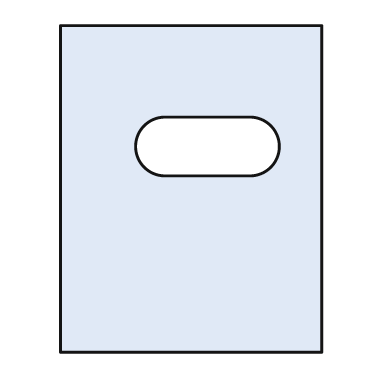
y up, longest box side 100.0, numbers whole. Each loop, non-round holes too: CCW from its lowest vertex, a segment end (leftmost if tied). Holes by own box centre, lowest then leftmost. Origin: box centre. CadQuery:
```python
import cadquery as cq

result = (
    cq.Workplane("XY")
    .moveTo(-40.0, -50.0)
    .lineTo(40.0, -50.0)
    .lineTo(40.0, 50.0)
    .lineTo(-40.0, 50.0)
    .close()
    .moveTo(-8.0, 4.0)
    .lineTo(18.0, 4.0)
    .threePointArc((27.0, 13.0), (18.0, 22.0))
    .lineTo(-8.0, 22.0)
    .threePointArc((-17.0, 13.0), (-8.0, 4.0))
    .close()
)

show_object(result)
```